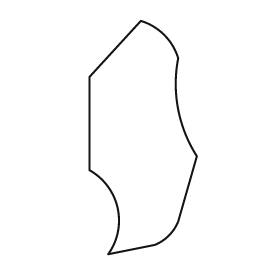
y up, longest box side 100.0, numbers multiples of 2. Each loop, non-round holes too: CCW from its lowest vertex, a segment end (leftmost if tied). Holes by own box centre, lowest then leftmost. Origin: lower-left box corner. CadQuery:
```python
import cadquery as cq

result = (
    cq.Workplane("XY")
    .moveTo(8.0, 0.0)
    .lineTo(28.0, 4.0)
    .threePointArc((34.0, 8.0), (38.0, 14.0))
    .lineTo(46.0, 42.0)
    .threePointArc((38.0, 62.0), (38.0, 84.0))
    .threePointArc((32.0, 94.0), (22.0, 100.0))
    .lineTo(0.0, 76.0)
    .lineTo(0.0, 36.0)
    .threePointArc((12.0, 20.0), (8.0, 0.0))
    .close()
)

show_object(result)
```